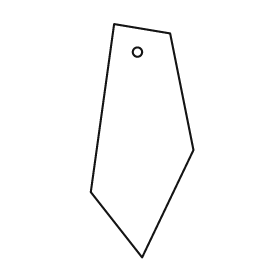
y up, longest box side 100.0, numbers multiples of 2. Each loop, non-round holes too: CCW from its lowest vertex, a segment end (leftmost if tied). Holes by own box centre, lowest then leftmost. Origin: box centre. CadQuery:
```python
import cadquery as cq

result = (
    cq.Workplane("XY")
    .moveTo(0.0, -50.0)
    .lineTo(22.0, -4.0)
    .lineTo(12.0, 46.0)
    .lineTo(-12.0, 50.0)
    .lineTo(-22.0, -22.0)
    .close()
    .moveTo(-2.0, 38.0)
    .circle(2.0)
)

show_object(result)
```